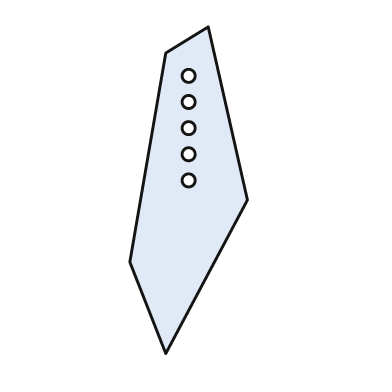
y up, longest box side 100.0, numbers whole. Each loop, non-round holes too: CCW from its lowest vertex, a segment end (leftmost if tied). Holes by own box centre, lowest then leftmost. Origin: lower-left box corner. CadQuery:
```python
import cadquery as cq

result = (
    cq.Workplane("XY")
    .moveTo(11.0, 0.0)
    .lineTo(36.0, 47.0)
    .lineTo(24.0, 100.0)
    .lineTo(11.0, 92.0)
    .lineTo(0.0, 28.0)
    .close()
    .moveTo(18.0, 53.0)
    .circle(2.0)
    .moveTo(18.0, 61.0)
    .circle(2.0)
    .moveTo(18.0, 69.0)
    .circle(2.0)
    .moveTo(18.0, 77.0)
    .circle(2.0)
    .moveTo(18.0, 85.0)
    .circle(2.0)
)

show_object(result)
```